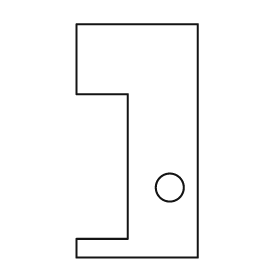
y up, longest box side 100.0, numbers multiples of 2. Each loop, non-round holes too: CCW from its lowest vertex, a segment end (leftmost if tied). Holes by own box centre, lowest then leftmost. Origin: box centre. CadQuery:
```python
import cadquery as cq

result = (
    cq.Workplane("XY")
    .moveTo(-26.0, -50.0)
    .lineTo(26.0, -50.0)
    .lineTo(26.0, 50.0)
    .lineTo(-26.0, 50.0)
    .lineTo(-26.0, 20.0)
    .lineTo(-4.0, 20.0)
    .lineTo(-4.0, -42.0)
    .lineTo(-26.0, -42.0)
    .close()
    .moveTo(14.0, -20.0)
    .circle(6.0)
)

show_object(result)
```